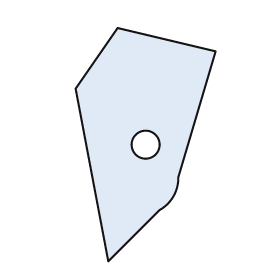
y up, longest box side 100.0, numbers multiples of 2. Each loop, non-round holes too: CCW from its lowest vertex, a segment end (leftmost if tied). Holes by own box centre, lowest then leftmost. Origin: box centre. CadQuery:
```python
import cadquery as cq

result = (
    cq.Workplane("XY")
    .moveTo(-16.0, -50.0)
    .lineTo(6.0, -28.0)
    .threePointArc((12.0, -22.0), (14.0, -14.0))
    .lineTo(30.0, 40.0)
    .lineTo(-12.0, 50.0)
    .lineTo(-30.0, 24.0)
    .close()
    .moveTo(0.0, 0.0)
    .circle(6.0)
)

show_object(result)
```